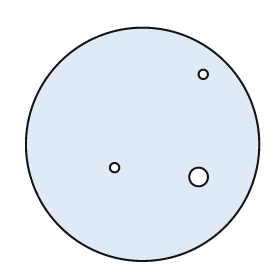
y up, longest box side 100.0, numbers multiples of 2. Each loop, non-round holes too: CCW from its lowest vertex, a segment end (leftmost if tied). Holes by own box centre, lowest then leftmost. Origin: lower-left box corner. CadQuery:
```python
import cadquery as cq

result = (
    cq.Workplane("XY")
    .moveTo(50.0, 50.0)
    .circle(50.0)
    .moveTo(74.0, 36.0)
    .circle(4.0)
    .moveTo(38.0, 40.0)
    .circle(2.0)
    .moveTo(76.0, 80.0)
    .circle(2.0)
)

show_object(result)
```